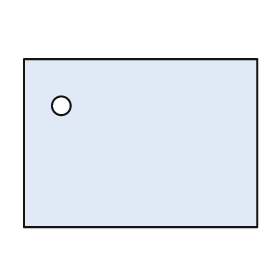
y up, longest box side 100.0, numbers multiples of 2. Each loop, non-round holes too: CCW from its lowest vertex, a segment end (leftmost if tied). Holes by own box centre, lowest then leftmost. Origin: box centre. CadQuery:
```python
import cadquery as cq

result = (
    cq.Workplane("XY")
    .moveTo(-50.0, -36.0)
    .lineTo(50.0, -36.0)
    .lineTo(50.0, 36.0)
    .lineTo(-50.0, 36.0)
    .close()
    .moveTo(-34.0, 16.0)
    .circle(4.0)
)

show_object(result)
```